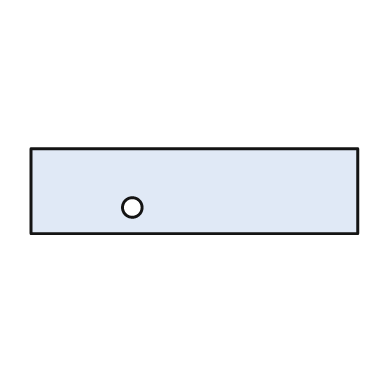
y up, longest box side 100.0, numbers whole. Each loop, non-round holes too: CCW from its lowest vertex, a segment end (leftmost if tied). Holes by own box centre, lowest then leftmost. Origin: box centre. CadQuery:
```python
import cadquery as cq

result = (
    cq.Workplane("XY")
    .moveTo(-50.0, -13.0)
    .lineTo(50.0, -13.0)
    .lineTo(50.0, 13.0)
    .lineTo(-50.0, 13.0)
    .close()
    .moveTo(-19.0, -5.0)
    .circle(3.0)
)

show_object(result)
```